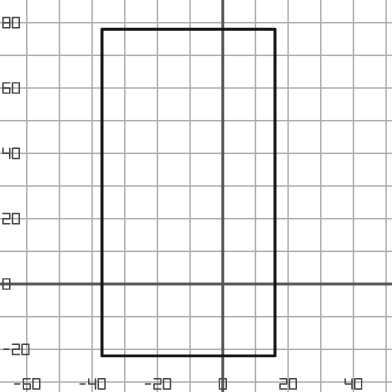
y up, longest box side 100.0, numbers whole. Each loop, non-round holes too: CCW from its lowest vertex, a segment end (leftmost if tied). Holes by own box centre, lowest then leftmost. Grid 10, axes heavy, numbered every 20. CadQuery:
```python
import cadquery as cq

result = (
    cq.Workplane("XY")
    .moveTo(-37.0, -22.0)
    .lineTo(16.0, -22.0)
    .lineTo(16.0, 78.0)
    .lineTo(-37.0, 78.0)
    .close()
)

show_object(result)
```